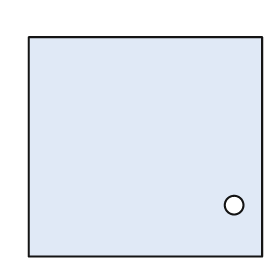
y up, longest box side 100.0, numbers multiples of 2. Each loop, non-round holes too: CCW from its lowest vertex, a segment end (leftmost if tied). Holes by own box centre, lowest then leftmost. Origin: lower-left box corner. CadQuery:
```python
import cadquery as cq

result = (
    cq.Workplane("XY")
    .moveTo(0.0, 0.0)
    .lineTo(100.0, 0.0)
    .lineTo(100.0, 94.0)
    .lineTo(0.0, 94.0)
    .close()
    .moveTo(88.0, 22.0)
    .circle(4.0)
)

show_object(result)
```